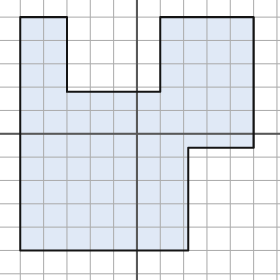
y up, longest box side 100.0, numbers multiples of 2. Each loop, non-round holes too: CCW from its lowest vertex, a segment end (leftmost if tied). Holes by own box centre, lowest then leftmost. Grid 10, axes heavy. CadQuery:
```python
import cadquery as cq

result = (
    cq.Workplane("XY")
    .moveTo(-50.0, -50.0)
    .lineTo(22.0, -50.0)
    .lineTo(22.0, -6.0)
    .lineTo(50.0, -6.0)
    .lineTo(50.0, 50.0)
    .lineTo(10.0, 50.0)
    .lineTo(10.0, 18.0)
    .lineTo(-30.0, 18.0)
    .lineTo(-30.0, 50.0)
    .lineTo(-50.0, 50.0)
    .close()
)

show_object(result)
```